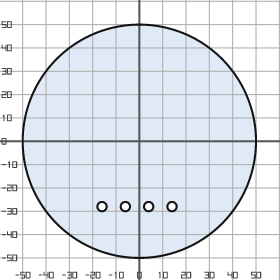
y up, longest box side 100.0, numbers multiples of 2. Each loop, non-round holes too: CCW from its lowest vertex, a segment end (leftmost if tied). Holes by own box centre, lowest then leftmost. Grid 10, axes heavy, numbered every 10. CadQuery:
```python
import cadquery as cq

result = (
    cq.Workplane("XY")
    .moveTo(0.0, 0.0)
    .circle(50.0)
    .moveTo(-16.0, -28.0)
    .circle(2.0)
    .moveTo(-6.0, -28.0)
    .circle(2.0)
    .moveTo(4.0, -28.0)
    .circle(2.0)
    .moveTo(14.0, -28.0)
    .circle(2.0)
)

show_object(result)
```